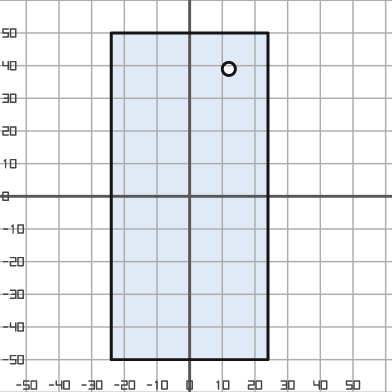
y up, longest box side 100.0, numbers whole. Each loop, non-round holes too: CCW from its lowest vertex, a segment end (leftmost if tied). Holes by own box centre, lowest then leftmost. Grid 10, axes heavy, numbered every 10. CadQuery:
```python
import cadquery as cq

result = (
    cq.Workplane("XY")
    .moveTo(-24.0, -50.0)
    .lineTo(24.0, -50.0)
    .lineTo(24.0, 50.0)
    .lineTo(-24.0, 50.0)
    .close()
    .moveTo(12.0, 39.0)
    .circle(2.0)
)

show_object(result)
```